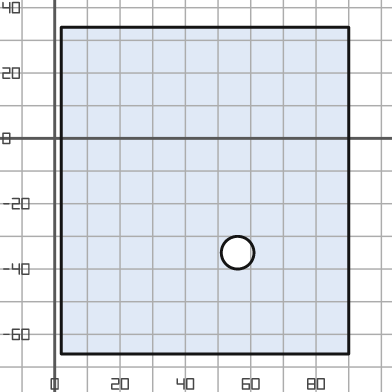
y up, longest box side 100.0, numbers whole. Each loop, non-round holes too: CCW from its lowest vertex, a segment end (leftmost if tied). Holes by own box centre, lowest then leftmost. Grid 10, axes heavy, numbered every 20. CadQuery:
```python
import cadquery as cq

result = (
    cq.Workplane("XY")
    .moveTo(2.0, -66.0)
    .lineTo(90.0, -66.0)
    .lineTo(90.0, 34.0)
    .lineTo(2.0, 34.0)
    .close()
    .moveTo(56.0, -35.0)
    .circle(5.0)
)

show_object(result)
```